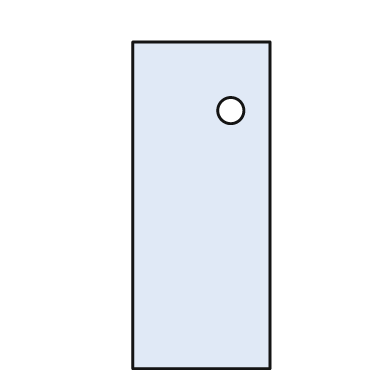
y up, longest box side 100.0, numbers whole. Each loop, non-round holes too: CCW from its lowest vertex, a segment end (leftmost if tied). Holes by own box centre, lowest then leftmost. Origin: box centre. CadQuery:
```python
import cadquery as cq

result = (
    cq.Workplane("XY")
    .moveTo(-21.0, -50.0)
    .lineTo(21.0, -50.0)
    .lineTo(21.0, 50.0)
    .lineTo(-21.0, 50.0)
    .close()
    .moveTo(9.0, 29.0)
    .circle(4.0)
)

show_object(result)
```